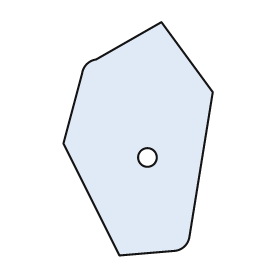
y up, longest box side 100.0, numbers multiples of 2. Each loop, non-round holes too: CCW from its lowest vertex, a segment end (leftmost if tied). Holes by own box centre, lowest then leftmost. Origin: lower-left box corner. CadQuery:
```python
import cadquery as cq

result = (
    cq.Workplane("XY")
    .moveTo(24.0, 0.0)
    .lineTo(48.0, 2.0)
    .threePointArc((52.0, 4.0), (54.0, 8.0))
    .lineTo(64.0, 70.0)
    .lineTo(42.0, 100.0)
    .lineTo(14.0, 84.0)
    .threePointArc((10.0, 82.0), (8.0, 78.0))
    .lineTo(0.0, 48.0)
    .close()
    .moveTo(36.0, 42.0)
    .circle(4.0)
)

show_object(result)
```